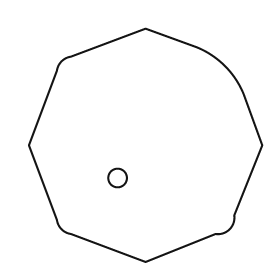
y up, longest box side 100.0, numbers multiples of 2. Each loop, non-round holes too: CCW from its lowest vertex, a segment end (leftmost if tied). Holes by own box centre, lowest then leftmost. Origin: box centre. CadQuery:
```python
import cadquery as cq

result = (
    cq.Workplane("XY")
    .moveTo(0.0, -50.0)
    .lineTo(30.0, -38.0)
    .threePointArc((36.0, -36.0), (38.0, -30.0))
    .lineTo(50.0, 0.0)
    .lineTo(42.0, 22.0)
    .threePointArc((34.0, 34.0), (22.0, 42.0))
    .lineTo(0.0, 50.0)
    .lineTo(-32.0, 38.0)
    .threePointArc((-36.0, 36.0), (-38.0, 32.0))
    .lineTo(-50.0, 0.0)
    .lineTo(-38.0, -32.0)
    .threePointArc((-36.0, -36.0), (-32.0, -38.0))
    .close()
    .moveTo(-12.0, -14.0)
    .circle(4.0)
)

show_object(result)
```